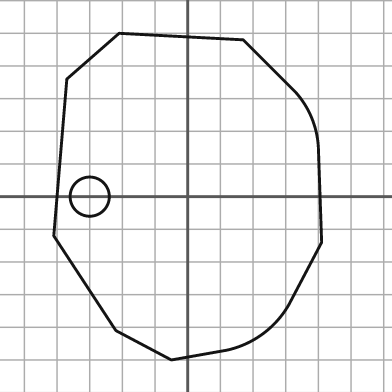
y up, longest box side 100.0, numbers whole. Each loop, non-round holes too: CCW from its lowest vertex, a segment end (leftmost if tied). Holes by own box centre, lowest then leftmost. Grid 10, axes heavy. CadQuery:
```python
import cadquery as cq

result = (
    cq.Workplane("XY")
    .moveTo(-5.0, -50.0)
    .lineTo(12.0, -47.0)
    .threePointArc((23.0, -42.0), (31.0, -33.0))
    .lineTo(41.0, -14.0)
    .lineTo(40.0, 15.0)
    .threePointArc((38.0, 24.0), (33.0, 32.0))
    .lineTo(17.0, 48.0)
    .lineTo(-21.0, 50.0)
    .lineTo(-37.0, 36.0)
    .lineTo(-41.0, -12.0)
    .lineTo(-22.0, -41.0)
    .close()
    .moveTo(-30.0, 0.0)
    .circle(6.0)
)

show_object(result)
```